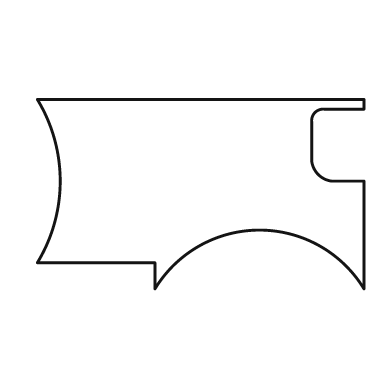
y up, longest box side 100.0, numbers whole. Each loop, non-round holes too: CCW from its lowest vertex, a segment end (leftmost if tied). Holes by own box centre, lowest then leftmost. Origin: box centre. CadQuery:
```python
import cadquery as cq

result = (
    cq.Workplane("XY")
    .moveTo(-14.0, -29.0)
    .threePointArc((18.0, -11.0), (50.0, -29.0))
    .lineTo(50.0, 4.0)
    .lineTo(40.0, 4.0)
    .threePointArc((36.0, 6.0), (34.0, 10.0))
    .lineTo(34.0, 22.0)
    .threePointArc((35.0, 25.0), (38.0, 26.0))
    .lineTo(50.0, 26.0)
    .lineTo(50.0, 29.0)
    .lineTo(-50.0, 29.0)
    .threePointArc((-43.0, 4.0), (-50.0, -21.0))
    .lineTo(-14.0, -21.0)
    .close()
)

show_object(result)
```